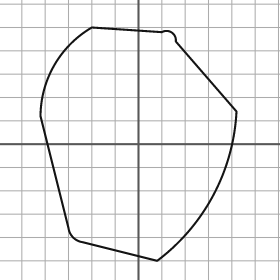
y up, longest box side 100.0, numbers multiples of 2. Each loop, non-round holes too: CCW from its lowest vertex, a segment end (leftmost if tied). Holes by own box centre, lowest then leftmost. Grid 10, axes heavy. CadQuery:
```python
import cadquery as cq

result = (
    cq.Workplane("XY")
    .moveTo(8.0, -50.0)
    .threePointArc((32.0, -22.0), (42.0, 14.0))
    .lineTo(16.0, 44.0)
    .threePointArc((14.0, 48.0), (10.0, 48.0))
    .lineTo(-20.0, 50.0)
    .threePointArc((-36.0, 34.0), (-42.0, 12.0))
    .lineTo(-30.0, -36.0)
    .threePointArc((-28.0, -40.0), (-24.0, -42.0))
    .close()
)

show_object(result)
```